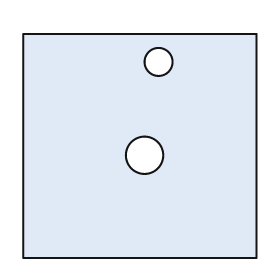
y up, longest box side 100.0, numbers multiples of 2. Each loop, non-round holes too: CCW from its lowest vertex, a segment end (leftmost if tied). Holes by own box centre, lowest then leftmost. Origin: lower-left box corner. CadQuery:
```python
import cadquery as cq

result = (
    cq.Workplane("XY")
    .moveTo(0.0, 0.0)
    .lineTo(100.0, 0.0)
    .lineTo(100.0, 96.0)
    .lineTo(0.0, 96.0)
    .close()
    .moveTo(52.0, 44.0)
    .circle(8.0)
    .moveTo(58.0, 84.0)
    .circle(6.0)
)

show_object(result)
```